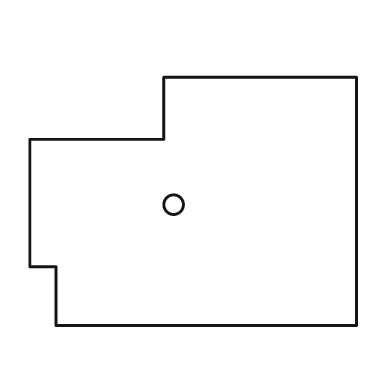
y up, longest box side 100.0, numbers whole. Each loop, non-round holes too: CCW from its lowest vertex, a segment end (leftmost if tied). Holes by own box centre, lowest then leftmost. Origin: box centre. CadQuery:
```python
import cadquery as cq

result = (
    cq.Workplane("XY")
    .moveTo(-42.0, -38.0)
    .lineTo(50.0, -38.0)
    .lineTo(50.0, 38.0)
    .lineTo(-9.0, 38.0)
    .lineTo(-9.0, 19.0)
    .lineTo(-50.0, 19.0)
    .lineTo(-50.0, -20.0)
    .lineTo(-42.0, -20.0)
    .close()
    .moveTo(-6.0, -1.0)
    .circle(3.0)
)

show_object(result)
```